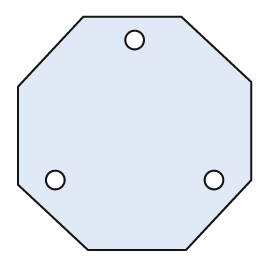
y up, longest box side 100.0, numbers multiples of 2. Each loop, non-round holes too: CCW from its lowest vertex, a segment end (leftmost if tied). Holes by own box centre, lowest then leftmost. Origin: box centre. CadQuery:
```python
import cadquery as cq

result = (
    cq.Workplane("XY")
    .moveTo(-20.0, -50.0)
    .lineTo(22.0, -50.0)
    .lineTo(50.0, -20.0)
    .lineTo(50.0, 22.0)
    .lineTo(20.0, 50.0)
    .lineTo(-22.0, 50.0)
    .lineTo(-50.0, 20.0)
    .lineTo(-50.0, -22.0)
    .close()
    .moveTo(-34.0, -20.0)
    .circle(4.0)
    .moveTo(34.0, -20.0)
    .circle(4.0)
    .moveTo(0.0, 40.0)
    .circle(4.0)
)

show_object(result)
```